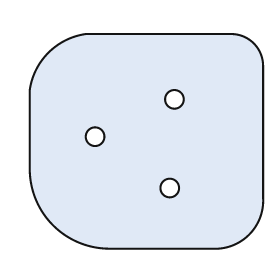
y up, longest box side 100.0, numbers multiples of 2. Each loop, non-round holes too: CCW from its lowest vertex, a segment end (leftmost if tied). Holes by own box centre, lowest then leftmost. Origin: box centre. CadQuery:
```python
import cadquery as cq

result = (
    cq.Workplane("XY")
    .moveTo(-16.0, -46.0)
    .lineTo(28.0, -46.0)
    .threePointArc((44.0, -40.0), (50.0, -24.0))
    .lineTo(50.0, 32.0)
    .threePointArc((46.0, 42.0), (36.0, 46.0))
    .lineTo(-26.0, 46.0)
    .threePointArc((-42.0, 38.0), (-50.0, 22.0))
    .lineTo(-50.0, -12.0)
    .threePointArc((-40.0, -36.0), (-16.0, -46.0))
    .close()
    .moveTo(10.0, -20.0)
    .circle(4.0)
    .moveTo(-22.0, 2.0)
    .circle(4.0)
    .moveTo(12.0, 18.0)
    .circle(4.0)
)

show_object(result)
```